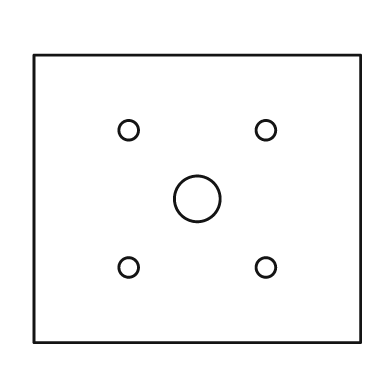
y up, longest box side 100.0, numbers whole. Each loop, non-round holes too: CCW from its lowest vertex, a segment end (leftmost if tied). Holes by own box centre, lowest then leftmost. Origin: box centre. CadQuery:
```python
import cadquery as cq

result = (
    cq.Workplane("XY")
    .moveTo(-50.0, -44.0)
    .lineTo(50.0, -44.0)
    .lineTo(50.0, 44.0)
    .lineTo(-50.0, 44.0)
    .close()
    .moveTo(-21.0, -21.0)
    .circle(3.0)
    .moveTo(21.0, -21.0)
    .circle(3.0)
    .moveTo(0.0, 0.0)
    .circle(7.0)
    .moveTo(-21.0, 21.0)
    .circle(3.0)
    .moveTo(21.0, 21.0)
    .circle(3.0)
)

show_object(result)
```